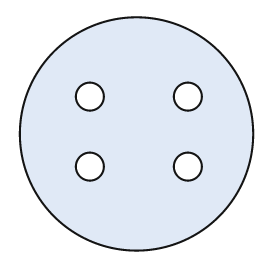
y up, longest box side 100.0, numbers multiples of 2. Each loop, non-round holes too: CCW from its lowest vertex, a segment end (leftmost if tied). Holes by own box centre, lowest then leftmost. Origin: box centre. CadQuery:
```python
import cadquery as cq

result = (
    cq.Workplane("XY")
    .moveTo(0.0, 0.0)
    .circle(50.0)
    .moveTo(-20.0, -14.0)
    .circle(6.0)
    .moveTo(22.0, -14.0)
    .circle(6.0)
    .moveTo(-20.0, 16.0)
    .circle(6.0)
    .moveTo(22.0, 16.0)
    .circle(6.0)
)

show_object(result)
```